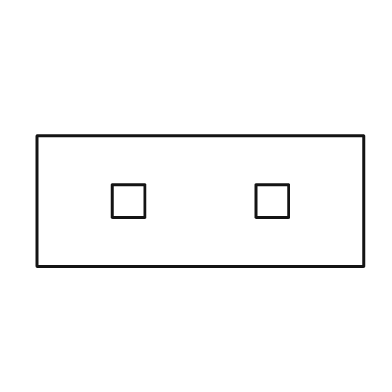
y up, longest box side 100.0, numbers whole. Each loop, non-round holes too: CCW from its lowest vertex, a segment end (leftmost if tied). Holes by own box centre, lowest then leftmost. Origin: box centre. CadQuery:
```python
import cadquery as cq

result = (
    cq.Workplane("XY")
    .moveTo(-50.0, -20.0)
    .lineTo(50.0, -20.0)
    .lineTo(50.0, 20.0)
    .lineTo(-50.0, 20.0)
    .close()
    .moveTo(-27.0, -5.0)
    .lineTo(-17.0, -5.0)
    .lineTo(-17.0, 5.0)
    .lineTo(-27.0, 5.0)
    .close()
    .moveTo(17.0, -5.0)
    .lineTo(27.0, -5.0)
    .lineTo(27.0, 5.0)
    .lineTo(17.0, 5.0)
    .close()
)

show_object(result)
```